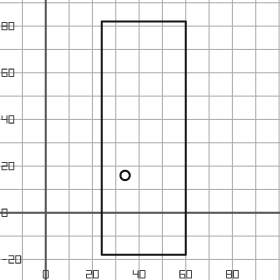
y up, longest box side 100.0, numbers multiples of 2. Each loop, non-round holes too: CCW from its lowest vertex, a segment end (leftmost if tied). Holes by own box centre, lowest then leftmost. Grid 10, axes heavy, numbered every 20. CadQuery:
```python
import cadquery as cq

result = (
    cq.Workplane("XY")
    .moveTo(24.0, -18.0)
    .lineTo(60.0, -18.0)
    .lineTo(60.0, 82.0)
    .lineTo(24.0, 82.0)
    .close()
    .moveTo(34.0, 16.0)
    .circle(2.0)
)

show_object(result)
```